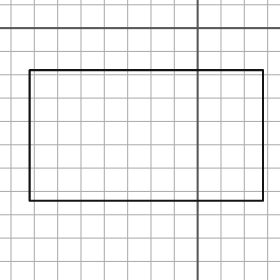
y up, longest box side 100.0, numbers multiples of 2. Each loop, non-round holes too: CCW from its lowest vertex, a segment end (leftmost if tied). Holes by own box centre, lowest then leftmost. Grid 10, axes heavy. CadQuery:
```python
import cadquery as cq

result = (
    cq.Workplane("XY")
    .moveTo(-72.0, -74.0)
    .lineTo(28.0, -74.0)
    .lineTo(28.0, -18.0)
    .lineTo(-72.0, -18.0)
    .close()
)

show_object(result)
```